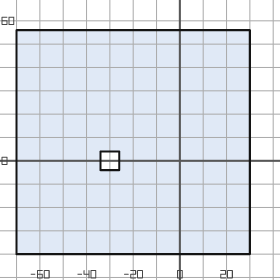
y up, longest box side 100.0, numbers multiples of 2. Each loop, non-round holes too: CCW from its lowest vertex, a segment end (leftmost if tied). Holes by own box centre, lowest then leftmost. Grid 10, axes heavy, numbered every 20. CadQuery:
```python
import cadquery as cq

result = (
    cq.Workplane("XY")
    .moveTo(-70.0, -40.0)
    .lineTo(30.0, -40.0)
    .lineTo(30.0, 56.0)
    .lineTo(-70.0, 56.0)
    .close()
    .moveTo(-34.0, -4.0)
    .lineTo(-26.0, -4.0)
    .lineTo(-26.0, 4.0)
    .lineTo(-34.0, 4.0)
    .close()
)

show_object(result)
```